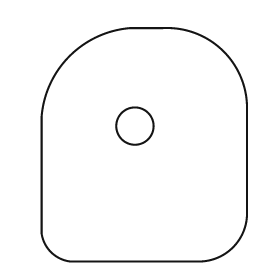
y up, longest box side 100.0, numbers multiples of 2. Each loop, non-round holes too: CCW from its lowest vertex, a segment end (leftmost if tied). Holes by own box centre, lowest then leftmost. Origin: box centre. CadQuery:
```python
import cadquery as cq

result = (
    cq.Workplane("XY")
    .moveTo(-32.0, -50.0)
    .lineTo(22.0, -50.0)
    .threePointArc((38.0, -44.0), (44.0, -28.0))
    .lineTo(44.0, 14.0)
    .threePointArc((34.0, 40.0), (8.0, 50.0))
    .lineTo(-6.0, 50.0)
    .threePointArc((-32.0, 38.0), (-44.0, 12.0))
    .lineTo(-44.0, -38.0)
    .threePointArc((-40.0, -46.0), (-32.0, -50.0))
    .close()
    .moveTo(-4.0, 8.0)
    .circle(8.0)
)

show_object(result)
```